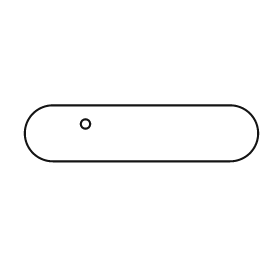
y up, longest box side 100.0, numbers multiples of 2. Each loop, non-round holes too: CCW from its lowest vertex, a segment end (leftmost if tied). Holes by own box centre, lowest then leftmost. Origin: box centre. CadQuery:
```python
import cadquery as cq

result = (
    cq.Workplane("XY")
    .moveTo(-38.0, -12.0)
    .lineTo(38.0, -12.0)
    .threePointArc((50.0, 0.0), (38.0, 12.0))
    .lineTo(-38.0, 12.0)
    .threePointArc((-50.0, 0.0), (-38.0, -12.0))
    .close()
    .moveTo(-24.0, 4.0)
    .circle(2.0)
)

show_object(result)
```